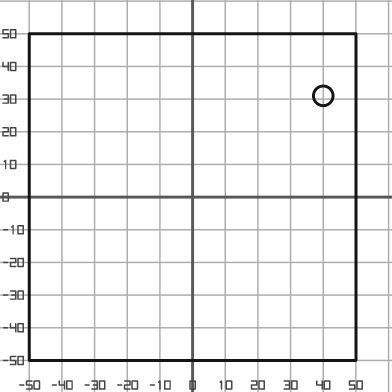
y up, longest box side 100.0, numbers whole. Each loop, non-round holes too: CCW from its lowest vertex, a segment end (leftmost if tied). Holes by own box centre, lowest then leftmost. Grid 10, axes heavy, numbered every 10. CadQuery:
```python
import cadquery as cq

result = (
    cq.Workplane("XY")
    .moveTo(-50.0, -50.0)
    .lineTo(50.0, -50.0)
    .lineTo(50.0, 50.0)
    .lineTo(-50.0, 50.0)
    .close()
    .moveTo(40.0, 31.0)
    .circle(3.0)
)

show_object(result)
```